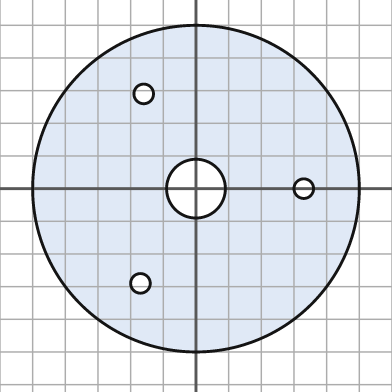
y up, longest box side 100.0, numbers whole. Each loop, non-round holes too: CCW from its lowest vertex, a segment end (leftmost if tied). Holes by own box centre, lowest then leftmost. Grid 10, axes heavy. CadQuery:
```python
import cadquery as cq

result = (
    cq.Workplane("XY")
    .moveTo(0.0, 0.0)
    .circle(50.0)
    .moveTo(-17.0, -29.0)
    .circle(3.0)
    .moveTo(0.0, 0.0)
    .circle(9.0)
    .moveTo(33.0, 0.0)
    .circle(3.0)
    .moveTo(-16.0, 29.0)
    .circle(3.0)
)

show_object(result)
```